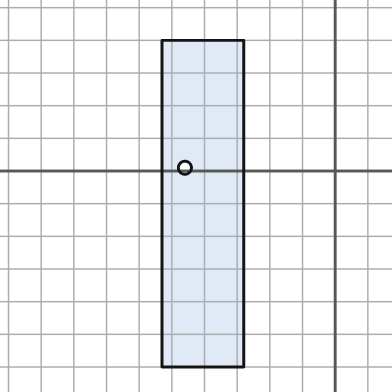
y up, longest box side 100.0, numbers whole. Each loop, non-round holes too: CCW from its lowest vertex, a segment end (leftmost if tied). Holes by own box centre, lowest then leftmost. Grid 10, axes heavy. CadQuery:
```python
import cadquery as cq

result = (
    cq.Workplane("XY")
    .moveTo(-53.0, -60.0)
    .lineTo(-28.0, -60.0)
    .lineTo(-28.0, 40.0)
    .lineTo(-53.0, 40.0)
    .close()
    .moveTo(-46.0, 1.0)
    .circle(2.0)
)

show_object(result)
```